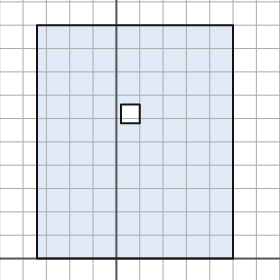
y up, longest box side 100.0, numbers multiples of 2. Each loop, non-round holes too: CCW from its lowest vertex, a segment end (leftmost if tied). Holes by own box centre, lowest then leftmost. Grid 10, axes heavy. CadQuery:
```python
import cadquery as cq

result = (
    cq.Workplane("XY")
    .moveTo(-34.0, 0.0)
    .lineTo(50.0, 0.0)
    .lineTo(50.0, 100.0)
    .lineTo(-34.0, 100.0)
    .close()
    .moveTo(2.0, 58.0)
    .lineTo(10.0, 58.0)
    .lineTo(10.0, 66.0)
    .lineTo(2.0, 66.0)
    .close()
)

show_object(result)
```